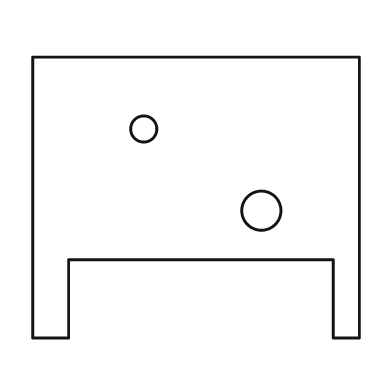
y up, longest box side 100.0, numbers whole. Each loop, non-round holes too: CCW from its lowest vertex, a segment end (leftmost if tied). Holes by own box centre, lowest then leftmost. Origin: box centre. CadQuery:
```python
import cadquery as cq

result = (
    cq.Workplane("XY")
    .moveTo(-50.0, -43.0)
    .lineTo(-39.0, -43.0)
    .lineTo(-39.0, -19.0)
    .lineTo(42.0, -19.0)
    .lineTo(42.0, -43.0)
    .lineTo(50.0, -43.0)
    .lineTo(50.0, 43.0)
    .lineTo(-50.0, 43.0)
    .close()
    .moveTo(20.0, -4.0)
    .circle(6.0)
    .moveTo(-16.0, 21.0)
    .circle(4.0)
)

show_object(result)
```